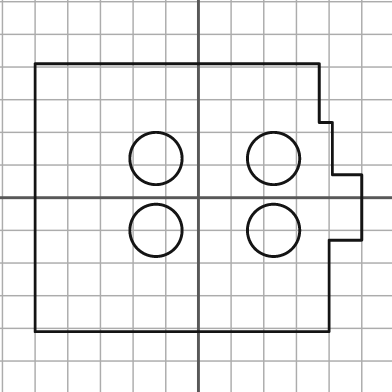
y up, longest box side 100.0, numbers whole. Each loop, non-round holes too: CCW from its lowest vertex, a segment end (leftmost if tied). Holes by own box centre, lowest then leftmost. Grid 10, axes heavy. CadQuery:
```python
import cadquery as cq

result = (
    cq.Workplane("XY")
    .moveTo(-50.0, -41.0)
    .lineTo(40.0, -41.0)
    .lineTo(40.0, -13.0)
    .lineTo(50.0, -13.0)
    .lineTo(50.0, 7.0)
    .lineTo(41.0, 7.0)
    .lineTo(41.0, 23.0)
    .lineTo(37.0, 23.0)
    .lineTo(37.0, 41.0)
    .lineTo(-50.0, 41.0)
    .close()
    .moveTo(-13.0, -10.0)
    .circle(8.0)
    .moveTo(23.0, -10.0)
    .circle(8.0)
    .moveTo(-13.0, 12.0)
    .circle(8.0)
    .moveTo(23.0, 12.0)
    .circle(8.0)
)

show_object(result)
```